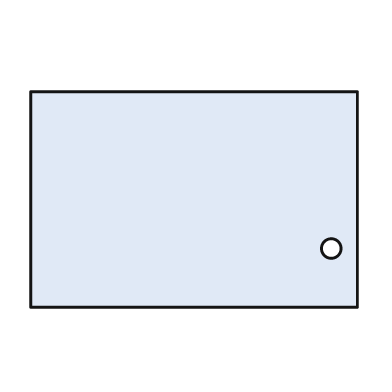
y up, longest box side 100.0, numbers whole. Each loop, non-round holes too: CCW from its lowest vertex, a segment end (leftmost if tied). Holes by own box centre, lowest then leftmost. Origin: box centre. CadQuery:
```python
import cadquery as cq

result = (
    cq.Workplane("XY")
    .moveTo(-50.0, -33.0)
    .lineTo(50.0, -33.0)
    .lineTo(50.0, 33.0)
    .lineTo(-50.0, 33.0)
    .close()
    .moveTo(42.0, -15.0)
    .circle(3.0)
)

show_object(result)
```